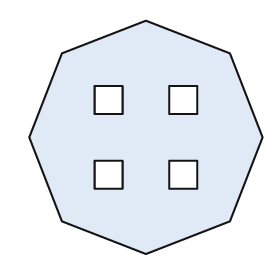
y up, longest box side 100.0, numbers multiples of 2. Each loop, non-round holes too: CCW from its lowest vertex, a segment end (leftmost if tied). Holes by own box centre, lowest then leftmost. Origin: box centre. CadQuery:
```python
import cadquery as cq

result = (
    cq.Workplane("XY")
    .moveTo(0.0, -50.0)
    .lineTo(36.0, -36.0)
    .lineTo(50.0, 0.0)
    .lineTo(36.0, 36.0)
    .lineTo(0.0, 50.0)
    .lineTo(-36.0, 36.0)
    .lineTo(-50.0, 0.0)
    .lineTo(-36.0, -36.0)
    .close()
    .moveTo(-22.0, -22.0)
    .lineTo(-10.0, -22.0)
    .lineTo(-10.0, -10.0)
    .lineTo(-22.0, -10.0)
    .close()
    .moveTo(10.0, -22.0)
    .lineTo(22.0, -22.0)
    .lineTo(22.0, -10.0)
    .lineTo(10.0, -10.0)
    .close()
    .moveTo(-22.0, 10.0)
    .lineTo(-10.0, 10.0)
    .lineTo(-10.0, 22.0)
    .lineTo(-22.0, 22.0)
    .close()
    .moveTo(10.0, 10.0)
    .lineTo(22.0, 10.0)
    .lineTo(22.0, 22.0)
    .lineTo(10.0, 22.0)
    .close()
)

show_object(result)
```